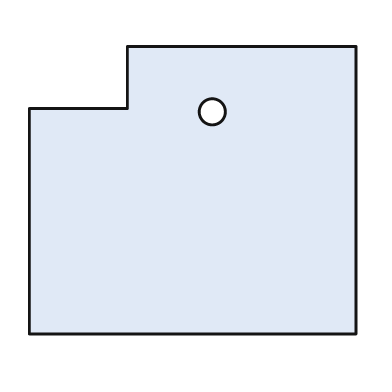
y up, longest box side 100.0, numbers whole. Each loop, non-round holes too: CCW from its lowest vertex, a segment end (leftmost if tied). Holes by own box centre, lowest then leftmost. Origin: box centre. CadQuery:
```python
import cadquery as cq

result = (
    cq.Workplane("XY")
    .moveTo(-50.0, -44.0)
    .lineTo(50.0, -44.0)
    .lineTo(50.0, 44.0)
    .lineTo(-20.0, 44.0)
    .lineTo(-20.0, 25.0)
    .lineTo(-50.0, 25.0)
    .close()
    .moveTo(6.0, 24.0)
    .circle(4.0)
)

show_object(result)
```